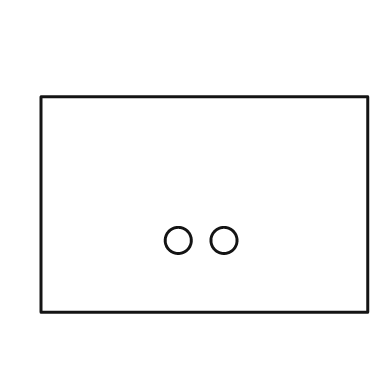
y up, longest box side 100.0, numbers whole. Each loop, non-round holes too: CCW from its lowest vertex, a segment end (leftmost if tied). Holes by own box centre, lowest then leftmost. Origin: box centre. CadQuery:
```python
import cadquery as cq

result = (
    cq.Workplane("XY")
    .moveTo(-50.0, -33.0)
    .lineTo(50.0, -33.0)
    .lineTo(50.0, 33.0)
    .lineTo(-50.0, 33.0)
    .close()
    .moveTo(-8.0, -11.0)
    .circle(4.0)
    .moveTo(6.0, -11.0)
    .circle(4.0)
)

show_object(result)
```